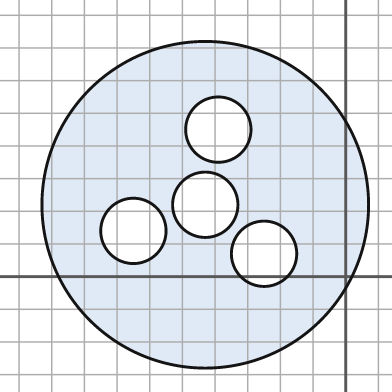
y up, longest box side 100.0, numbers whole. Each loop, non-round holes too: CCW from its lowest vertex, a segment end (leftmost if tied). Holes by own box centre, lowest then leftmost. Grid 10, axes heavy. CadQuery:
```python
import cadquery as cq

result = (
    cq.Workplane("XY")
    .moveTo(-43.0, 22.0)
    .circle(50.0)
    .moveTo(-25.0, 7.0)
    .circle(10.0)
    .moveTo(-65.0, 14.0)
    .circle(10.0)
    .moveTo(-43.0, 22.0)
    .circle(10.0)
    .moveTo(-39.0, 45.0)
    .circle(10.0)
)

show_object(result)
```